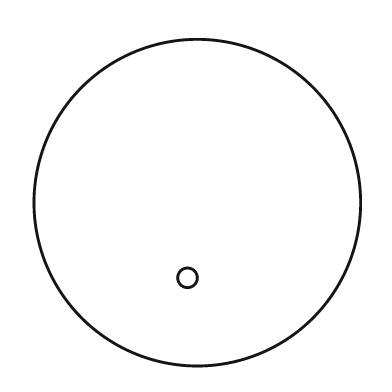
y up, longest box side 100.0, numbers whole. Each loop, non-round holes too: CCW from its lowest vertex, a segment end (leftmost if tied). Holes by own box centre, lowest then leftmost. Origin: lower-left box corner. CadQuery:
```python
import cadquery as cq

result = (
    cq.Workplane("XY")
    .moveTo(50.0, 50.0)
    .circle(50.0)
    .moveTo(47.0, 27.0)
    .circle(3.0)
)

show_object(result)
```